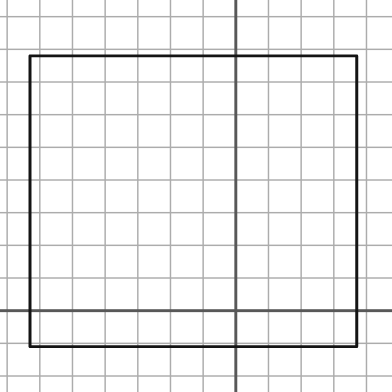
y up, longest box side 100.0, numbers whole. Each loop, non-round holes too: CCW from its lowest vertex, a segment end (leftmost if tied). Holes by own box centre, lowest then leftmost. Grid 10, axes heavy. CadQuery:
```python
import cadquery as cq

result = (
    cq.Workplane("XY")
    .moveTo(-63.0, -11.0)
    .lineTo(37.0, -11.0)
    .lineTo(37.0, 78.0)
    .lineTo(-63.0, 78.0)
    .close()
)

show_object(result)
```